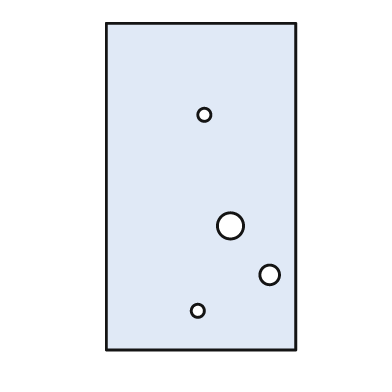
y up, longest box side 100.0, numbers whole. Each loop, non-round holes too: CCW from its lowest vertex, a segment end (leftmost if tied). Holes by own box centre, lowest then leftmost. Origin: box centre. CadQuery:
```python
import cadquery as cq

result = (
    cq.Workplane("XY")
    .moveTo(-29.0, -50.0)
    .lineTo(29.0, -50.0)
    .lineTo(29.0, 50.0)
    .lineTo(-29.0, 50.0)
    .close()
    .moveTo(-1.0, -38.0)
    .circle(2.0)
    .moveTo(21.0, -27.0)
    .circle(3.0)
    .moveTo(9.0, -12.0)
    .circle(4.0)
    .moveTo(1.0, 22.0)
    .circle(2.0)
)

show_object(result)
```